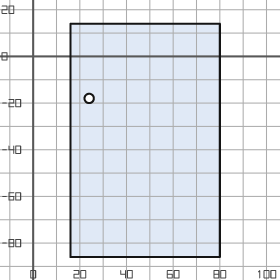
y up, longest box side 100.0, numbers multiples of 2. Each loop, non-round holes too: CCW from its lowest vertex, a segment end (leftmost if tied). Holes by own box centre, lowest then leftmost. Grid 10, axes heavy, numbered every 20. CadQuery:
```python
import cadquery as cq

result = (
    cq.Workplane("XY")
    .moveTo(16.0, -86.0)
    .lineTo(80.0, -86.0)
    .lineTo(80.0, 14.0)
    .lineTo(16.0, 14.0)
    .close()
    .moveTo(24.0, -18.0)
    .circle(2.0)
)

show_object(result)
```